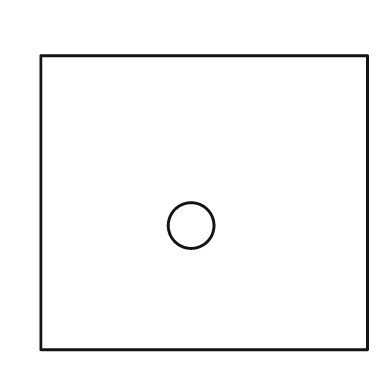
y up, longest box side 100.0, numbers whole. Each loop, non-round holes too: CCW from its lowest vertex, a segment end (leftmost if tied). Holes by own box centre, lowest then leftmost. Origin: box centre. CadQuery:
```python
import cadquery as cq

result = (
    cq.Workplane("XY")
    .moveTo(-50.0, -45.0)
    .lineTo(50.0, -45.0)
    .lineTo(50.0, 45.0)
    .lineTo(-50.0, 45.0)
    .close()
    .moveTo(-4.0, -7.0)
    .circle(7.0)
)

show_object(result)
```